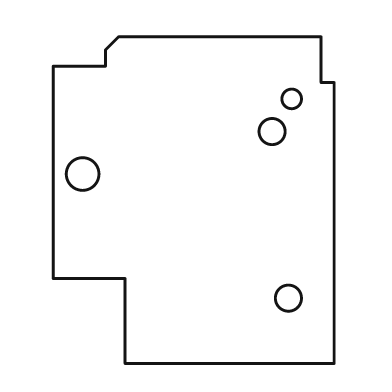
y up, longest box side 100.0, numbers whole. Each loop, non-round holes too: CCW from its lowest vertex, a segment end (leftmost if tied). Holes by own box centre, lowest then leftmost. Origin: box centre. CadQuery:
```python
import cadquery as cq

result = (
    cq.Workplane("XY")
    .moveTo(-21.0, -50.0)
    .lineTo(43.0, -50.0)
    .lineTo(43.0, 36.0)
    .lineTo(39.0, 36.0)
    .lineTo(39.0, 50.0)
    .lineTo(-23.0, 50.0)
    .lineTo(-27.0, 46.0)
    .lineTo(-27.0, 41.0)
    .lineTo(-43.0, 41.0)
    .lineTo(-43.0, -24.0)
    .lineTo(-21.0, -24.0)
    .close()
    .moveTo(29.0, -30.0)
    .circle(4.0)
    .moveTo(-34.0, 8.0)
    .circle(5.0)
    .moveTo(24.0, 21.0)
    .circle(4.0)
    .moveTo(30.0, 31.0)
    .circle(3.0)
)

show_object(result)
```